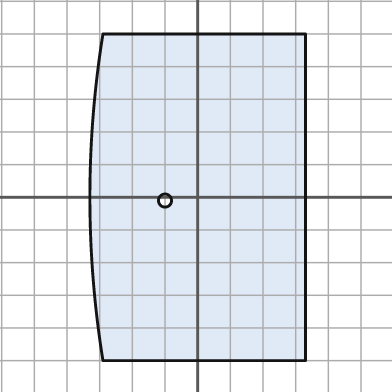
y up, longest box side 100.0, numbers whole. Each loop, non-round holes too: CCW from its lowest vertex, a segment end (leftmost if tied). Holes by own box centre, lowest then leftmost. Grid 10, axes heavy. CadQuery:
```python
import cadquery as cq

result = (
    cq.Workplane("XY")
    .moveTo(-29.0, -50.0)
    .lineTo(33.0, -50.0)
    .lineTo(33.0, 50.0)
    .lineTo(-29.0, 50.0)
    .threePointArc((-33.0, 0.0), (-29.0, -50.0))
    .close()
    .moveTo(-10.0, -1.0)
    .circle(2.0)
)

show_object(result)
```